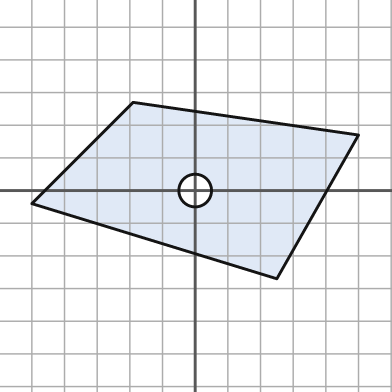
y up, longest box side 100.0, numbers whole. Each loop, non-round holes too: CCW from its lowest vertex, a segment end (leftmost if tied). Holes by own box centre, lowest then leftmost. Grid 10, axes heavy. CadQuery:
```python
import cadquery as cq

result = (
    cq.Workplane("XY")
    .moveTo(25.0, -27.0)
    .lineTo(50.0, 17.0)
    .lineTo(-19.0, 27.0)
    .lineTo(-50.0, -4.0)
    .close()
    .moveTo(0.0, 0.0)
    .circle(5.0)
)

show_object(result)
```